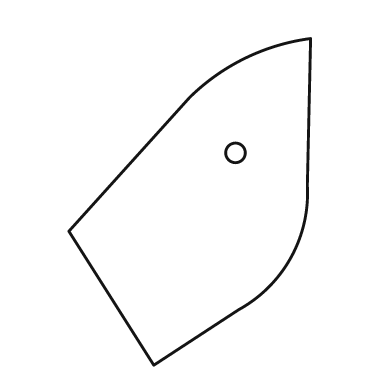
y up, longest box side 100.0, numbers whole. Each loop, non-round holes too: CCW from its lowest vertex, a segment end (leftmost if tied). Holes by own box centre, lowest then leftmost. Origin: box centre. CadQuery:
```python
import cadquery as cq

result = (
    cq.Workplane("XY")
    .moveTo(-11.0, -50.0)
    .lineTo(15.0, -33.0)
    .threePointArc((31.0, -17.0), (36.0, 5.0))
    .lineTo(37.0, 50.0)
    .threePointArc((17.0, 44.0), (0.0, 32.0))
    .lineTo(-37.0, -9.0)
    .close()
    .moveTo(14.0, 15.0)
    .circle(3.0)
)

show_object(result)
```